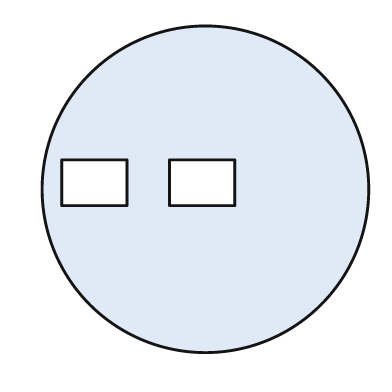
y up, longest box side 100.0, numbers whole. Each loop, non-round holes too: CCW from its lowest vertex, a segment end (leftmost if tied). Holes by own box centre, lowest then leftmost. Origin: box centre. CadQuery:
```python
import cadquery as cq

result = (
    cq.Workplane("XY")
    .moveTo(0.0, 0.0)
    .circle(50.0)
    .moveTo(-44.0, -5.0)
    .lineTo(-24.0, -5.0)
    .lineTo(-24.0, 9.0)
    .lineTo(-44.0, 9.0)
    .close()
    .moveTo(-11.0, -5.0)
    .lineTo(9.0, -5.0)
    .lineTo(9.0, 9.0)
    .lineTo(-11.0, 9.0)
    .close()
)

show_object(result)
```